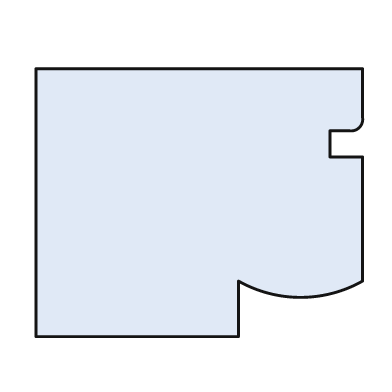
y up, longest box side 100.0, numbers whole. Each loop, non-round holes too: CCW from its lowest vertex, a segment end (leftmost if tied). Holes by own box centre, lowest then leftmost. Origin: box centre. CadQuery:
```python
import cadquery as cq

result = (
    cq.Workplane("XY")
    .moveTo(-50.0, -41.0)
    .lineTo(12.0, -41.0)
    .lineTo(12.0, -24.0)
    .threePointArc((31.0, -29.0), (50.0, -24.0))
    .lineTo(50.0, 14.0)
    .lineTo(40.0, 14.0)
    .lineTo(40.0, 22.0)
    .lineTo(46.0, 22.0)
    .threePointArc((49.0, 23.0), (50.0, 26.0))
    .lineTo(50.0, 41.0)
    .lineTo(-50.0, 41.0)
    .close()
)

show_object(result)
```